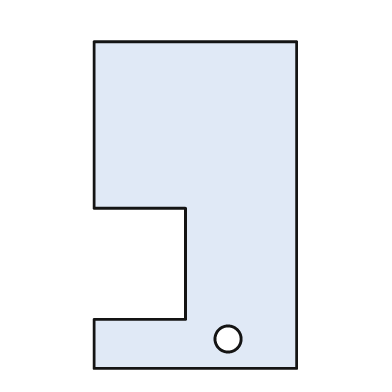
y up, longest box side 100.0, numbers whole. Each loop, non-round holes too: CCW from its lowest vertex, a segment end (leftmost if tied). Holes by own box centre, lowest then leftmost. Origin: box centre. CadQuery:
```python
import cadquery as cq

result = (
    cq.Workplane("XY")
    .moveTo(-31.0, -50.0)
    .lineTo(31.0, -50.0)
    .lineTo(31.0, 50.0)
    .lineTo(-31.0, 50.0)
    .lineTo(-31.0, -1.0)
    .lineTo(-3.0, -1.0)
    .lineTo(-3.0, -35.0)
    .lineTo(-31.0, -35.0)
    .close()
    .moveTo(10.0, -41.0)
    .circle(4.0)
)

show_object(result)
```